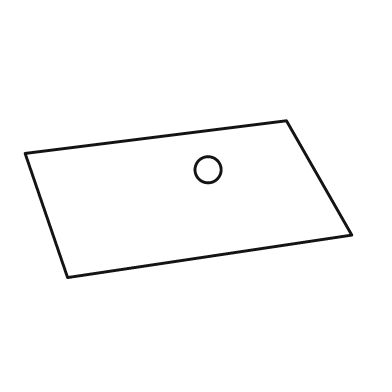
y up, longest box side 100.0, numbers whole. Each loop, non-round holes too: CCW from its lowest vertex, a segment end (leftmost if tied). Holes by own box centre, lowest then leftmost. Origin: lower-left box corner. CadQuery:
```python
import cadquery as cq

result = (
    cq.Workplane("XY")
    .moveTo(13.0, 0.0)
    .lineTo(100.0, 13.0)
    .lineTo(80.0, 48.0)
    .lineTo(0.0, 38.0)
    .close()
    .moveTo(56.0, 33.0)
    .circle(4.0)
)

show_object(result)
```